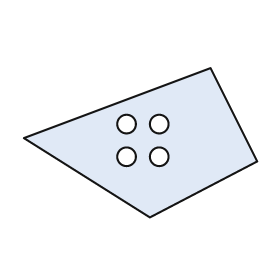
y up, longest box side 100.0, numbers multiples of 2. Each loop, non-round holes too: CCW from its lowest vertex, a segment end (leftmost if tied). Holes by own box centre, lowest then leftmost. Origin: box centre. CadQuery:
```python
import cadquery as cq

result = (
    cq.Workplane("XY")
    .moveTo(4.0, -32.0)
    .lineTo(50.0, -8.0)
    .lineTo(30.0, 32.0)
    .lineTo(-50.0, 2.0)
    .close()
    .moveTo(-6.0, -6.0)
    .circle(4.0)
    .moveTo(8.0, -6.0)
    .circle(4.0)
    .moveTo(-6.0, 8.0)
    .circle(4.0)
    .moveTo(8.0, 8.0)
    .circle(4.0)
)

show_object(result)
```